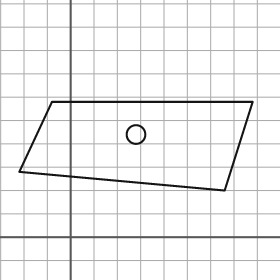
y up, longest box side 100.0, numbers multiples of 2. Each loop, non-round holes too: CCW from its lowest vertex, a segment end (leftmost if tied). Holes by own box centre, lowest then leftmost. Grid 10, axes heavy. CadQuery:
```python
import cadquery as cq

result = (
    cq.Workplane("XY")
    .moveTo(66.0, 20.0)
    .lineTo(78.0, 58.0)
    .lineTo(-8.0, 58.0)
    .lineTo(-22.0, 28.0)
    .close()
    .moveTo(28.0, 44.0)
    .circle(4.0)
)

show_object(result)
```